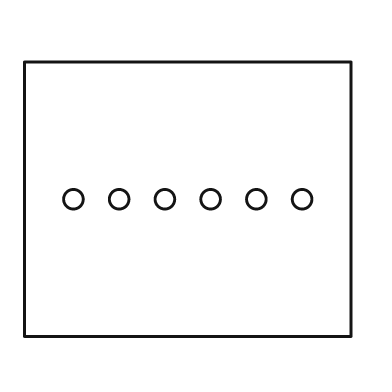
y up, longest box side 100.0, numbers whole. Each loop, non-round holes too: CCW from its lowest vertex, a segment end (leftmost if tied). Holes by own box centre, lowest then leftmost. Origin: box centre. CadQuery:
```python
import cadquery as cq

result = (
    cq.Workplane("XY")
    .moveTo(-50.0, -42.0)
    .lineTo(50.0, -42.0)
    .lineTo(50.0, 42.0)
    .lineTo(-50.0, 42.0)
    .close()
    .moveTo(-35.0, 0.0)
    .circle(3.0)
    .moveTo(-21.0, 0.0)
    .circle(3.0)
    .moveTo(-7.0, 0.0)
    .circle(3.0)
    .moveTo(7.0, 0.0)
    .circle(3.0)
    .moveTo(21.0, 0.0)
    .circle(3.0)
    .moveTo(35.0, 0.0)
    .circle(3.0)
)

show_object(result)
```